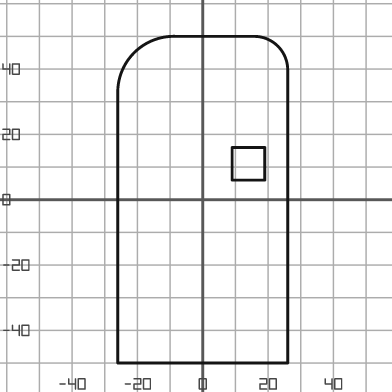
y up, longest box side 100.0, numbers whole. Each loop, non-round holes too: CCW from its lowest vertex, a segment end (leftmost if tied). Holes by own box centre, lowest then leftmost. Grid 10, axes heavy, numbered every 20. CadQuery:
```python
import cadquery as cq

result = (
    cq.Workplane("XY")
    .moveTo(-26.0, -50.0)
    .lineTo(26.0, -50.0)
    .lineTo(26.0, 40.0)
    .threePointArc((23.0, 47.0), (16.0, 50.0))
    .lineTo(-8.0, 50.0)
    .threePointArc((-21.0, 45.0), (-26.0, 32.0))
    .close()
    .moveTo(9.0, 6.0)
    .lineTo(19.0, 6.0)
    .lineTo(19.0, 16.0)
    .lineTo(9.0, 16.0)
    .close()
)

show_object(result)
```